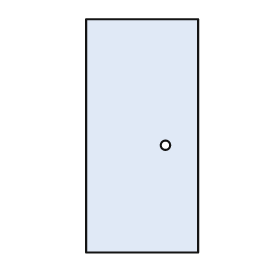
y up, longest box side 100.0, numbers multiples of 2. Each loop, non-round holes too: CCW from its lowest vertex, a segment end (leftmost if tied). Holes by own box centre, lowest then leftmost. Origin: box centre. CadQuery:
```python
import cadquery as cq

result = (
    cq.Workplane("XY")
    .moveTo(-24.0, -50.0)
    .lineTo(24.0, -50.0)
    .lineTo(24.0, 50.0)
    .lineTo(-24.0, 50.0)
    .close()
    .moveTo(10.0, -4.0)
    .circle(2.0)
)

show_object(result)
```